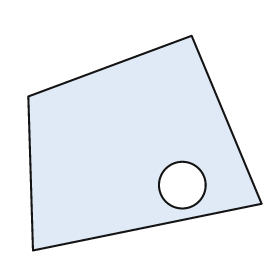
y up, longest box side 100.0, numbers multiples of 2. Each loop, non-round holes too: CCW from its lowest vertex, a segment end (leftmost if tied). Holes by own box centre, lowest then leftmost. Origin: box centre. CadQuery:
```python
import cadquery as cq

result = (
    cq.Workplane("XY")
    .moveTo(-48.0, -46.0)
    .lineTo(50.0, -26.0)
    .lineTo(20.0, 46.0)
    .lineTo(-50.0, 20.0)
    .close()
    .moveTo(16.0, -18.0)
    .circle(10.0)
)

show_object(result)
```